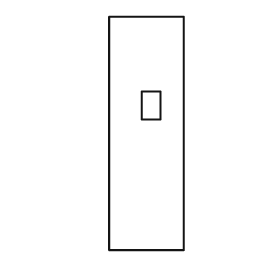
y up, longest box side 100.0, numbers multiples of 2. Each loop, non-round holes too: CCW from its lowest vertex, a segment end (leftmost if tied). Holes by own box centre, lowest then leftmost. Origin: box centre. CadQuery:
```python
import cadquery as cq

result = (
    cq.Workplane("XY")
    .moveTo(-16.0, -50.0)
    .lineTo(16.0, -50.0)
    .lineTo(16.0, 50.0)
    .lineTo(-16.0, 50.0)
    .close()
    .moveTo(-2.0, 6.0)
    .lineTo(6.0, 6.0)
    .lineTo(6.0, 18.0)
    .lineTo(-2.0, 18.0)
    .close()
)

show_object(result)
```